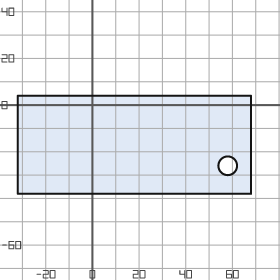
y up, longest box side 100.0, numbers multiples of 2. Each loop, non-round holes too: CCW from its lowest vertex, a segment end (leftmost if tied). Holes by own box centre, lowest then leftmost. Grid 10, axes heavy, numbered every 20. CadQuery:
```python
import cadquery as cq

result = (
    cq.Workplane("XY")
    .moveTo(-32.0, -38.0)
    .lineTo(68.0, -38.0)
    .lineTo(68.0, 4.0)
    .lineTo(-32.0, 4.0)
    .close()
    .moveTo(58.0, -26.0)
    .circle(4.0)
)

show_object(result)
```